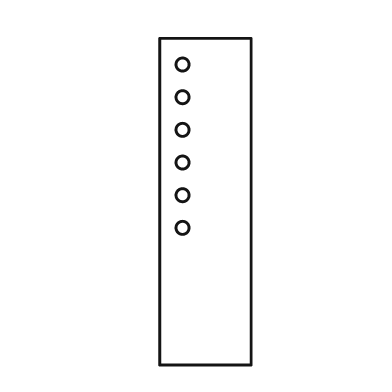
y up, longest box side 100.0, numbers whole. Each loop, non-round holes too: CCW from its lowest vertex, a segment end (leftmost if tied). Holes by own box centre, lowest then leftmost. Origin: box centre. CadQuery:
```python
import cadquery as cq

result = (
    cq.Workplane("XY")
    .moveTo(-14.0, -50.0)
    .lineTo(14.0, -50.0)
    .lineTo(14.0, 50.0)
    .lineTo(-14.0, 50.0)
    .close()
    .moveTo(-7.0, -8.0)
    .circle(2.0)
    .moveTo(-7.0, 2.0)
    .circle(2.0)
    .moveTo(-7.0, 12.0)
    .circle(2.0)
    .moveTo(-7.0, 22.0)
    .circle(2.0)
    .moveTo(-7.0, 32.0)
    .circle(2.0)
    .moveTo(-7.0, 42.0)
    .circle(2.0)
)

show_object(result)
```